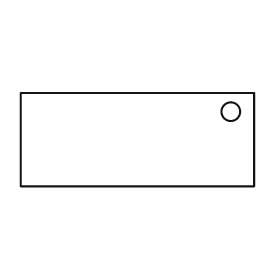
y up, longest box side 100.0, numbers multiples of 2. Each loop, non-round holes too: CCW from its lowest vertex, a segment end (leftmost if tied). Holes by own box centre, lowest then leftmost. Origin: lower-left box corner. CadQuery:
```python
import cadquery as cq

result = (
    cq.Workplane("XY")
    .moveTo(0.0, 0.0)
    .lineTo(100.0, 0.0)
    .lineTo(100.0, 40.0)
    .lineTo(0.0, 40.0)
    .close()
    .moveTo(90.0, 32.0)
    .circle(4.0)
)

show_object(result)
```